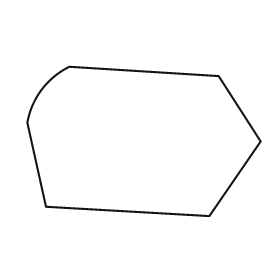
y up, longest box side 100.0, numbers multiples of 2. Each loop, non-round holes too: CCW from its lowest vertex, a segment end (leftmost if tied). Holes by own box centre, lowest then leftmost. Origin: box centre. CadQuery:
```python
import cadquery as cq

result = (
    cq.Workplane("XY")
    .moveTo(28.0, -32.0)
    .lineTo(50.0, 0.0)
    .lineTo(32.0, 28.0)
    .lineTo(-32.0, 32.0)
    .threePointArc((-44.0, 22.0), (-50.0, 8.0))
    .lineTo(-42.0, -28.0)
    .close()
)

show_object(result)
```